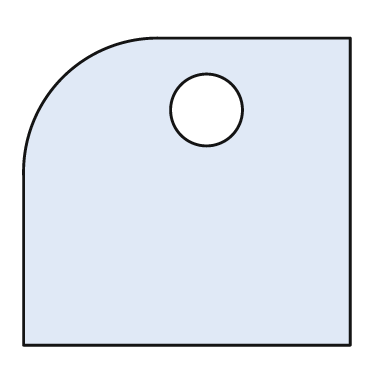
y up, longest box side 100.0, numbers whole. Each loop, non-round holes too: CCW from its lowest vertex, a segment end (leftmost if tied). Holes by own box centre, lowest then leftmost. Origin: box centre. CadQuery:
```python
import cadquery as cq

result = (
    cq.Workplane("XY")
    .moveTo(-50.0, -47.0)
    .lineTo(50.0, -47.0)
    .lineTo(50.0, 47.0)
    .lineTo(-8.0, 47.0)
    .threePointArc((-38.0, 35.0), (-50.0, 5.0))
    .close()
    .moveTo(6.0, 25.0)
    .circle(11.0)
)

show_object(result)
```